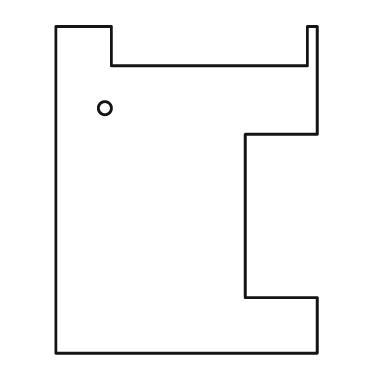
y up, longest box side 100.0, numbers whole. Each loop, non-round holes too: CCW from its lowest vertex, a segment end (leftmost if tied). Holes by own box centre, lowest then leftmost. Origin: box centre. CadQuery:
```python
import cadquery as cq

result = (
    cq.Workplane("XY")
    .moveTo(-40.0, -50.0)
    .lineTo(40.0, -50.0)
    .lineTo(40.0, -33.0)
    .lineTo(18.0, -33.0)
    .lineTo(18.0, 17.0)
    .lineTo(40.0, 17.0)
    .lineTo(40.0, 50.0)
    .lineTo(37.0, 50.0)
    .lineTo(37.0, 38.0)
    .lineTo(-23.0, 38.0)
    .lineTo(-23.0, 50.0)
    .lineTo(-40.0, 50.0)
    .close()
    .moveTo(-25.0, 25.0)
    .circle(2.0)
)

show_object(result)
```